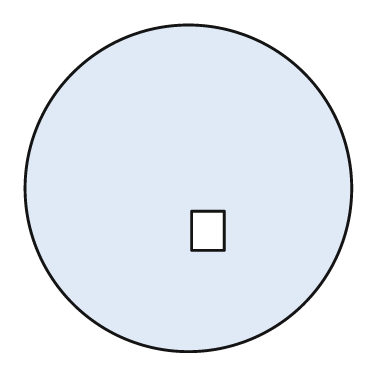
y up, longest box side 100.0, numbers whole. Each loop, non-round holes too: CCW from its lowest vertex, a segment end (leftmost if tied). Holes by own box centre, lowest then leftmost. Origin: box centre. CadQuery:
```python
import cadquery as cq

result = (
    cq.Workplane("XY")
    .moveTo(0.0, 0.0)
    .circle(50.0)
    .moveTo(1.0, -19.0)
    .lineTo(11.0, -19.0)
    .lineTo(11.0, -7.0)
    .lineTo(1.0, -7.0)
    .close()
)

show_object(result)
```